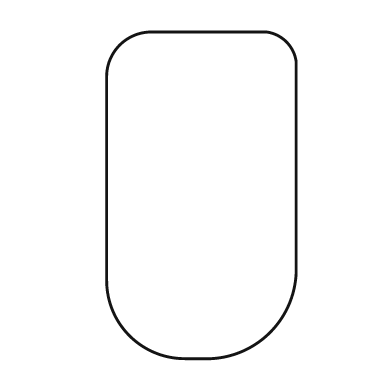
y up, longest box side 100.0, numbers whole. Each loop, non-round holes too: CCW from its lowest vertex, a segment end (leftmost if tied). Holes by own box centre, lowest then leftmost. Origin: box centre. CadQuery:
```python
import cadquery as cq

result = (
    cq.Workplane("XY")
    .moveTo(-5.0, -50.0)
    .lineTo(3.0, -50.0)
    .threePointArc((21.0, -42.0), (29.0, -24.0))
    .lineTo(29.0, 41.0)
    .threePointArc((26.0, 47.0), (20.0, 50.0))
    .lineTo(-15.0, 50.0)
    .threePointArc((-25.0, 46.0), (-29.0, 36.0))
    .lineTo(-29.0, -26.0)
    .threePointArc((-22.0, -43.0), (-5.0, -50.0))
    .close()
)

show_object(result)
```